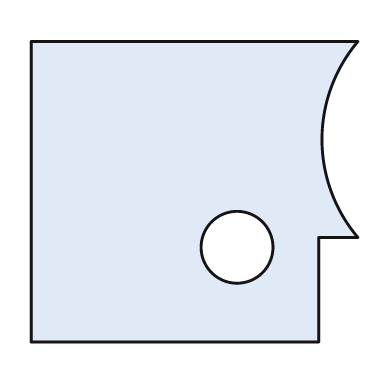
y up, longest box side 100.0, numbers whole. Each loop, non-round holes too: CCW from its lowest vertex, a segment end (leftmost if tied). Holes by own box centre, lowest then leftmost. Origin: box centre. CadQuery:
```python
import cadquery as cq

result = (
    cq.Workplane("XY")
    .moveTo(-50.0, -46.0)
    .lineTo(38.0, -46.0)
    .lineTo(38.0, -14.0)
    .lineTo(50.0, -14.0)
    .threePointArc((39.0, 16.0), (50.0, 46.0))
    .lineTo(-50.0, 46.0)
    .close()
    .moveTo(13.0, -17.0)
    .circle(11.0)
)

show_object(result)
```